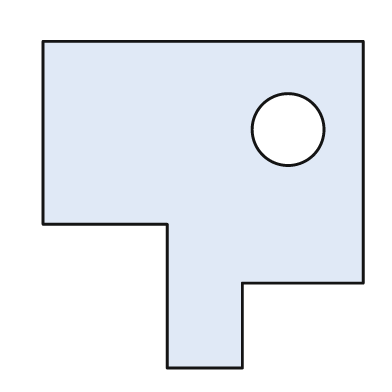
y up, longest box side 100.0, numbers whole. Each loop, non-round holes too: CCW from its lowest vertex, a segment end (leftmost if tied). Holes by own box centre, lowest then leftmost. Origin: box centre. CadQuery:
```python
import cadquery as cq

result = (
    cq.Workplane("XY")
    .moveTo(-11.0, -50.0)
    .lineTo(12.0, -50.0)
    .lineTo(12.0, -24.0)
    .lineTo(49.0, -24.0)
    .lineTo(49.0, 50.0)
    .lineTo(-49.0, 50.0)
    .lineTo(-49.0, -6.0)
    .lineTo(-11.0, -6.0)
    .close()
    .moveTo(26.0, 23.0)
    .circle(11.0)
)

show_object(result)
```